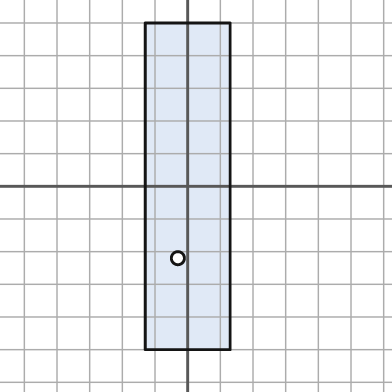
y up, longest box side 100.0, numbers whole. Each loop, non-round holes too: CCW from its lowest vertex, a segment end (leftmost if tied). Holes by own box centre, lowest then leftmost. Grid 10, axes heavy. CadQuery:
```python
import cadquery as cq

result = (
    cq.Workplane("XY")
    .moveTo(-13.0, -50.0)
    .lineTo(13.0, -50.0)
    .lineTo(13.0, 50.0)
    .lineTo(-13.0, 50.0)
    .close()
    .moveTo(-3.0, -22.0)
    .circle(2.0)
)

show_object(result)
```